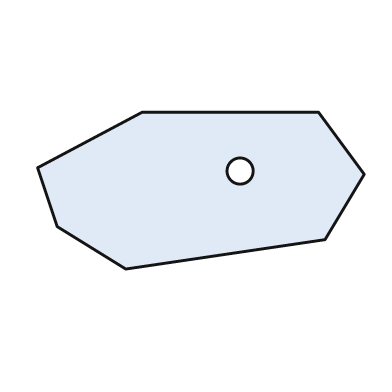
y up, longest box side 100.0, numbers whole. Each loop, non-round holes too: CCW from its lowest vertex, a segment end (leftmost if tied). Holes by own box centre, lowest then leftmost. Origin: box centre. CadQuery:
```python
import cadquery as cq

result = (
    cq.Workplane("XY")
    .moveTo(-23.0, -24.0)
    .lineTo(38.0, -15.0)
    .lineTo(50.0, 5.0)
    .lineTo(36.0, 24.0)
    .lineTo(-18.0, 24.0)
    .lineTo(-50.0, 7.0)
    .lineTo(-44.0, -11.0)
    .close()
    .moveTo(12.0, 6.0)
    .circle(4.0)
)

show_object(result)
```